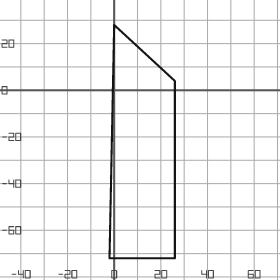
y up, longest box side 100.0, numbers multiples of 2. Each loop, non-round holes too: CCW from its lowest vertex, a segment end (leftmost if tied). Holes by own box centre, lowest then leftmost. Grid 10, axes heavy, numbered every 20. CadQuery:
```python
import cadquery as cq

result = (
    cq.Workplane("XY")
    .moveTo(-2.0, -72.0)
    .lineTo(26.0, -72.0)
    .lineTo(26.0, 4.0)
    .lineTo(0.0, 28.0)
    .close()
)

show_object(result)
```